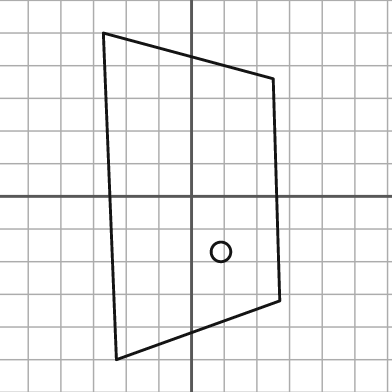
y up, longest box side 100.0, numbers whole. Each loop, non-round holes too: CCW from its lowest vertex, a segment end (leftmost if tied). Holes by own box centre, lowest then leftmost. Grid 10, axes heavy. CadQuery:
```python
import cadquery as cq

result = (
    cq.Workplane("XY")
    .moveTo(-23.0, -50.0)
    .lineTo(27.0, -32.0)
    .lineTo(25.0, 36.0)
    .lineTo(-27.0, 50.0)
    .close()
    .moveTo(9.0, -17.0)
    .circle(3.0)
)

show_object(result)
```